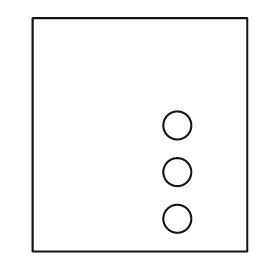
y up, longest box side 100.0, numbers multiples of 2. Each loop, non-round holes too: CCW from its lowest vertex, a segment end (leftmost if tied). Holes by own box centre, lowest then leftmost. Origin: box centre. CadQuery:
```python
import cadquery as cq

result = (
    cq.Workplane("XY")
    .moveTo(-46.0, -50.0)
    .lineTo(46.0, -50.0)
    .lineTo(46.0, 50.0)
    .lineTo(-46.0, 50.0)
    .close()
    .moveTo(16.0, -36.0)
    .circle(6.0)
    .moveTo(16.0, -16.0)
    .circle(6.0)
    .moveTo(16.0, 4.0)
    .circle(6.0)
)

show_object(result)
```